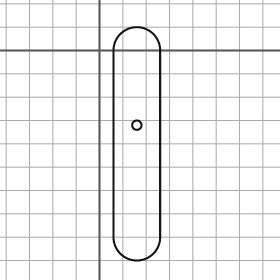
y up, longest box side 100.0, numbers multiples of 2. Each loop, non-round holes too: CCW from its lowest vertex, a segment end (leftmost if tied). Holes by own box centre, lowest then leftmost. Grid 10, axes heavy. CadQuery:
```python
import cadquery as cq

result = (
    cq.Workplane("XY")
    .moveTo(6.0, -80.0)
    .threePointArc((16.0, -90.0), (26.0, -80.0))
    .lineTo(26.0, 0.0)
    .threePointArc((16.0, 10.0), (6.0, 0.0))
    .close()
    .moveTo(16.0, -32.0)
    .circle(2.0)
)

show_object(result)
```